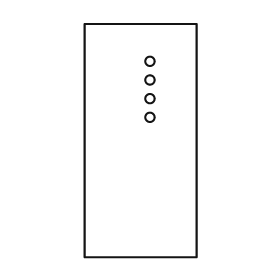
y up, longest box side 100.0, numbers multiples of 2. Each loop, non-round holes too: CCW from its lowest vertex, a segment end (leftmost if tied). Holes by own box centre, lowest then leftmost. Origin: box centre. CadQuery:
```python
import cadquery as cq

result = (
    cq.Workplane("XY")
    .moveTo(-24.0, -50.0)
    .lineTo(24.0, -50.0)
    .lineTo(24.0, 50.0)
    .lineTo(-24.0, 50.0)
    .close()
    .moveTo(4.0, 10.0)
    .circle(2.0)
    .moveTo(4.0, 18.0)
    .circle(2.0)
    .moveTo(4.0, 26.0)
    .circle(2.0)
    .moveTo(4.0, 34.0)
    .circle(2.0)
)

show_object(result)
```